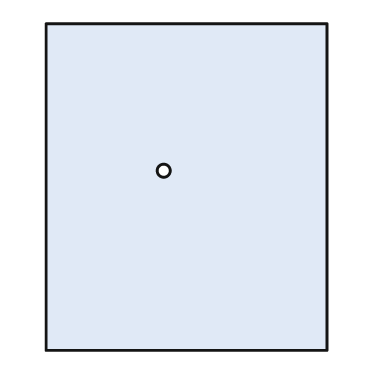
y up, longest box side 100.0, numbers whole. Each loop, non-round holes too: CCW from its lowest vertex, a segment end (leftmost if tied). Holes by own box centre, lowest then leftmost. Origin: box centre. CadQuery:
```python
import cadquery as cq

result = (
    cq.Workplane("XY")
    .moveTo(-43.0, -50.0)
    .lineTo(43.0, -50.0)
    .lineTo(43.0, 50.0)
    .lineTo(-43.0, 50.0)
    .close()
    .moveTo(-7.0, 5.0)
    .circle(2.0)
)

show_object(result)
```